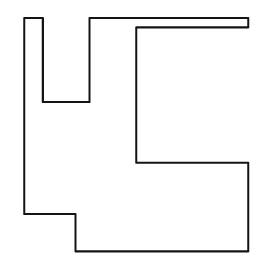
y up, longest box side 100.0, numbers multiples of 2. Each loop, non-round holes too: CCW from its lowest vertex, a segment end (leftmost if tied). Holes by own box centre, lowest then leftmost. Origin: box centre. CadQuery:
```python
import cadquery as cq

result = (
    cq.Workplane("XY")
    .moveTo(-26.0, -50.0)
    .lineTo(48.0, -50.0)
    .lineTo(48.0, -12.0)
    .lineTo(0.0, -12.0)
    .lineTo(0.0, 46.0)
    .lineTo(48.0, 46.0)
    .lineTo(48.0, 50.0)
    .lineTo(-20.0, 50.0)
    .lineTo(-20.0, 14.0)
    .lineTo(-40.0, 14.0)
    .lineTo(-40.0, 50.0)
    .lineTo(-48.0, 50.0)
    .lineTo(-48.0, -34.0)
    .lineTo(-26.0, -34.0)
    .close()
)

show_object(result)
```